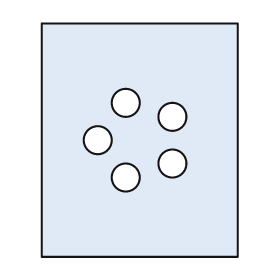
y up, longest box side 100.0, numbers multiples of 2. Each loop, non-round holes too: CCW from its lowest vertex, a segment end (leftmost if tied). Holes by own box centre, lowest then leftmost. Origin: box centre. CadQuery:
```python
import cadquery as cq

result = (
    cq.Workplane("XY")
    .moveTo(-42.0, -50.0)
    .lineTo(42.0, -50.0)
    .lineTo(42.0, 50.0)
    .lineTo(-42.0, 50.0)
    .close()
    .moveTo(-6.0, -16.0)
    .circle(6.0)
    .moveTo(14.0, -10.0)
    .circle(6.0)
    .moveTo(-18.0, 0.0)
    .circle(6.0)
    .moveTo(14.0, 10.0)
    .circle(6.0)
    .moveTo(-6.0, 16.0)
    .circle(6.0)
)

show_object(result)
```